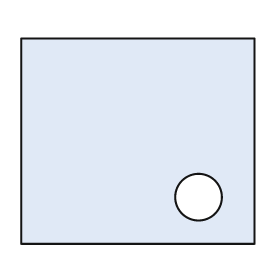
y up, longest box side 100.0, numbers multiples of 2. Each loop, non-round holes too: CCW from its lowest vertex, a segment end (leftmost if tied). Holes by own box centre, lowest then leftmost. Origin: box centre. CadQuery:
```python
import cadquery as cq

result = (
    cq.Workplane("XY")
    .moveTo(-50.0, -44.0)
    .lineTo(50.0, -44.0)
    .lineTo(50.0, 44.0)
    .lineTo(-50.0, 44.0)
    .close()
    .moveTo(26.0, -24.0)
    .circle(10.0)
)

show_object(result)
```